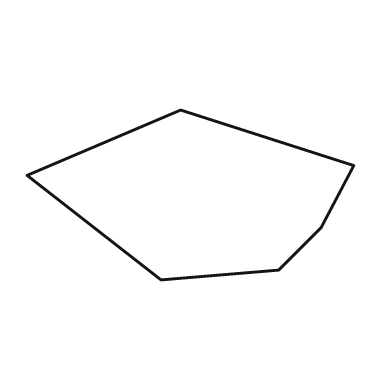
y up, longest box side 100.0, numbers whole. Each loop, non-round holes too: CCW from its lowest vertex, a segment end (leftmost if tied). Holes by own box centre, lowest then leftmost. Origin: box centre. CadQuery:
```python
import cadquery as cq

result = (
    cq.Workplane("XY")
    .moveTo(-9.0, -26.0)
    .lineTo(27.0, -23.0)
    .lineTo(40.0, -10.0)
    .lineTo(50.0, 9.0)
    .lineTo(-3.0, 26.0)
    .lineTo(-50.0, 6.0)
    .close()
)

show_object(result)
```